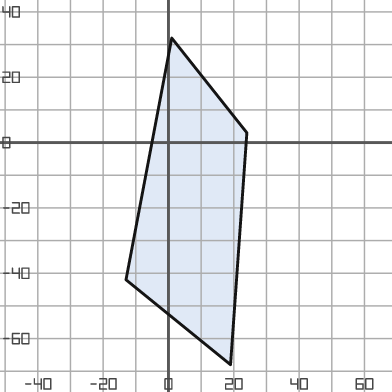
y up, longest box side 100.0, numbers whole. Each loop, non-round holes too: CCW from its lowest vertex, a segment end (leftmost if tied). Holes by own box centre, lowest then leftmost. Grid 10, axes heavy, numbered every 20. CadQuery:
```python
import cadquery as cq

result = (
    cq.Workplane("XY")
    .moveTo(19.0, -68.0)
    .lineTo(24.0, 3.0)
    .lineTo(1.0, 32.0)
    .lineTo(-13.0, -42.0)
    .close()
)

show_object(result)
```